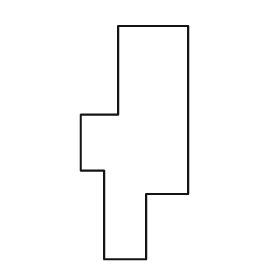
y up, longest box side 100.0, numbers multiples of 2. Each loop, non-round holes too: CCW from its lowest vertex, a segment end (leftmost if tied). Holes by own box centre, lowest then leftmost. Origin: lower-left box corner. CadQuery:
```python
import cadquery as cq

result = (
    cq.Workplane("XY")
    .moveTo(10.0, 0.0)
    .lineTo(28.0, 0.0)
    .lineTo(28.0, 28.0)
    .lineTo(46.0, 28.0)
    .lineTo(46.0, 100.0)
    .lineTo(16.0, 100.0)
    .lineTo(16.0, 62.0)
    .lineTo(0.0, 62.0)
    .lineTo(0.0, 38.0)
    .lineTo(10.0, 38.0)
    .close()
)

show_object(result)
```